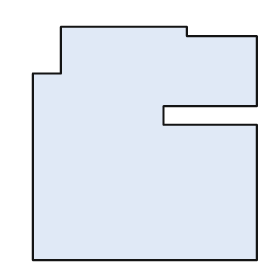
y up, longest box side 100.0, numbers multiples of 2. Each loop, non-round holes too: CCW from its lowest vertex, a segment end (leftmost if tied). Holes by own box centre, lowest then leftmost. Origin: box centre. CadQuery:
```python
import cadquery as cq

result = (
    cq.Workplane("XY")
    .moveTo(-48.0, -50.0)
    .lineTo(48.0, -50.0)
    .lineTo(48.0, 8.0)
    .lineTo(8.0, 8.0)
    .lineTo(8.0, 16.0)
    .lineTo(48.0, 16.0)
    .lineTo(48.0, 46.0)
    .lineTo(18.0, 46.0)
    .lineTo(18.0, 50.0)
    .lineTo(-36.0, 50.0)
    .lineTo(-36.0, 30.0)
    .lineTo(-48.0, 30.0)
    .close()
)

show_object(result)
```